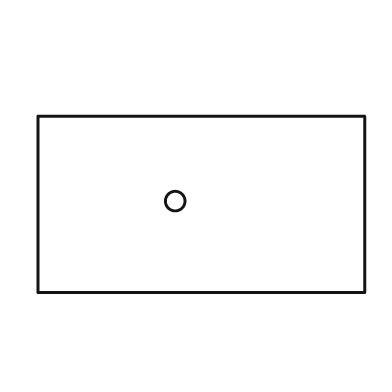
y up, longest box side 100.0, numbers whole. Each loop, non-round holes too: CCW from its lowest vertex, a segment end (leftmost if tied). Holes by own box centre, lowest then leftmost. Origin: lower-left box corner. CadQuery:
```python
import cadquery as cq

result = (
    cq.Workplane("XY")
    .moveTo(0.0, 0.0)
    .lineTo(100.0, 0.0)
    .lineTo(100.0, 54.0)
    .lineTo(0.0, 54.0)
    .close()
    .moveTo(42.0, 28.0)
    .circle(3.0)
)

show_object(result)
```